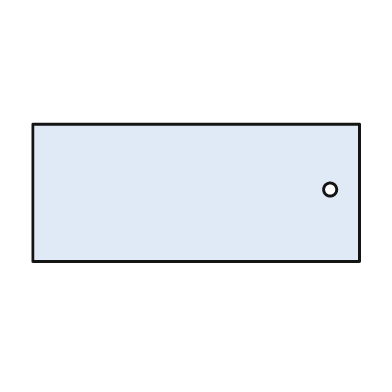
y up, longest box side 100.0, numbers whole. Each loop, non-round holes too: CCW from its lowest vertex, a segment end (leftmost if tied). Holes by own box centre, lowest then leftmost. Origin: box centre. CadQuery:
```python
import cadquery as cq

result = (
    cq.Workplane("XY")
    .moveTo(-50.0, -21.0)
    .lineTo(50.0, -21.0)
    .lineTo(50.0, 21.0)
    .lineTo(-50.0, 21.0)
    .close()
    .moveTo(41.0, 1.0)
    .circle(2.0)
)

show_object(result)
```